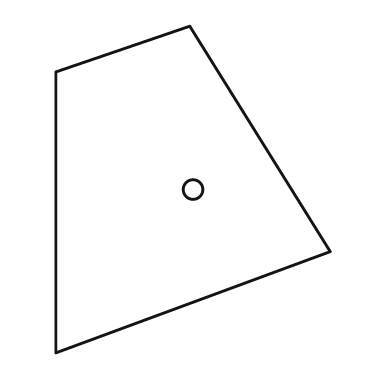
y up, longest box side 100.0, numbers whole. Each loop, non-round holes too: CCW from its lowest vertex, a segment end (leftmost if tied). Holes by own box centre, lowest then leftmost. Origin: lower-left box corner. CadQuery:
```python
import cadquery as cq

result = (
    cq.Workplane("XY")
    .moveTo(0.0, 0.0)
    .lineTo(84.0, 31.0)
    .lineTo(41.0, 100.0)
    .lineTo(0.0, 86.0)
    .close()
    .moveTo(42.0, 50.0)
    .circle(3.0)
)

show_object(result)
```